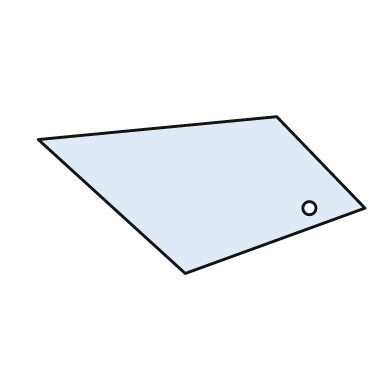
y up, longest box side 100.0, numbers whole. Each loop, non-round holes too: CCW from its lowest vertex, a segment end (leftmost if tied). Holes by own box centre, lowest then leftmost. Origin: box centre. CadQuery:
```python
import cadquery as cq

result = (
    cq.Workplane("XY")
    .moveTo(-5.0, -24.0)
    .lineTo(50.0, -4.0)
    .lineTo(23.0, 24.0)
    .lineTo(-50.0, 17.0)
    .close()
    .moveTo(33.0, -4.0)
    .circle(2.0)
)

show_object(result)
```